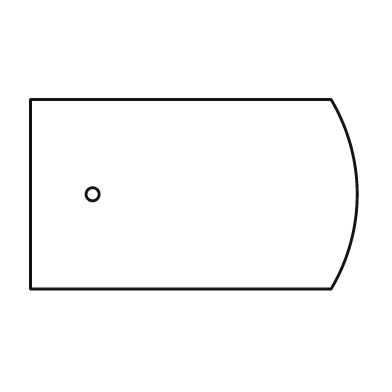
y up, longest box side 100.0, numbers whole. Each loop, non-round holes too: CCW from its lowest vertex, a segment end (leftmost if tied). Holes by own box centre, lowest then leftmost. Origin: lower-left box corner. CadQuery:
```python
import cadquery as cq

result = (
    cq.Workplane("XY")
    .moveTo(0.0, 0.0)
    .lineTo(92.0, 0.0)
    .threePointArc((100.0, 29.0), (92.0, 58.0))
    .lineTo(0.0, 58.0)
    .close()
    .moveTo(19.0, 29.0)
    .circle(2.0)
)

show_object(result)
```